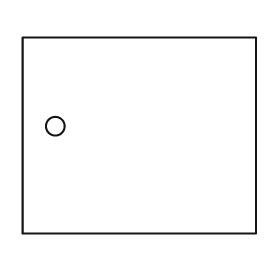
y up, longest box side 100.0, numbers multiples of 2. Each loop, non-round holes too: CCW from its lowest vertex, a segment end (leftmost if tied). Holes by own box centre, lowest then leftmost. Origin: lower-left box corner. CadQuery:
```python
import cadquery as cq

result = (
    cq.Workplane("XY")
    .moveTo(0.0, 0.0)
    .lineTo(100.0, 0.0)
    .lineTo(100.0, 84.0)
    .lineTo(0.0, 84.0)
    .close()
    .moveTo(14.0, 46.0)
    .circle(4.0)
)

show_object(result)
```